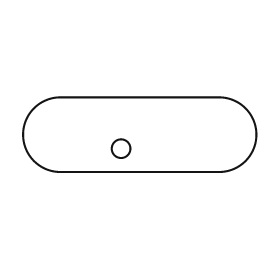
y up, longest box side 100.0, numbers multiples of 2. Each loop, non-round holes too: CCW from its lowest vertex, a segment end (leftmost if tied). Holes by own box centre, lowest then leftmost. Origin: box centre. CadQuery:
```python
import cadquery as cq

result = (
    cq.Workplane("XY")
    .moveTo(-34.0, -16.0)
    .lineTo(34.0, -16.0)
    .threePointArc((50.0, 0.0), (34.0, 16.0))
    .lineTo(-34.0, 16.0)
    .threePointArc((-50.0, 0.0), (-34.0, -16.0))
    .close()
    .moveTo(-8.0, -6.0)
    .circle(4.0)
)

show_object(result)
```